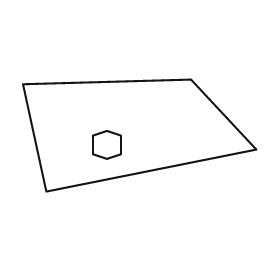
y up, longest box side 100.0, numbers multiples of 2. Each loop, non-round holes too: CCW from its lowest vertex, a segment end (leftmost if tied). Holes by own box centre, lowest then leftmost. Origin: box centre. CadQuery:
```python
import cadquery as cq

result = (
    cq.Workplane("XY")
    .moveTo(-40.0, -24.0)
    .lineTo(50.0, -6.0)
    .lineTo(22.0, 24.0)
    .lineTo(-50.0, 22.0)
    .close()
    .moveTo(-14.0, -10.0)
    .lineTo(-8.0, -8.0)
    .lineTo(-8.0, 0.0)
    .lineTo(-14.0, 2.0)
    .lineTo(-20.0, 0.0)
    .lineTo(-20.0, -8.0)
    .close()
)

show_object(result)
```